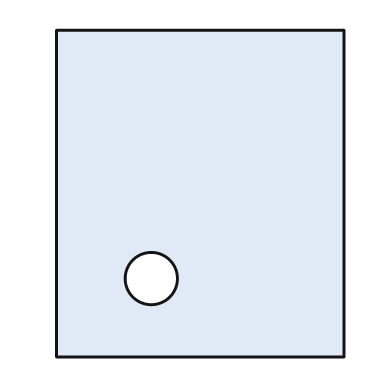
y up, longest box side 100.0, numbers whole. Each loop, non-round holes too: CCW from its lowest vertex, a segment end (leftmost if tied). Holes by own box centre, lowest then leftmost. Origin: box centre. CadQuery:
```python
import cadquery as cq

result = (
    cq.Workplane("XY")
    .moveTo(-44.0, -50.0)
    .lineTo(44.0, -50.0)
    .lineTo(44.0, 50.0)
    .lineTo(-44.0, 50.0)
    .close()
    .moveTo(-15.0, -26.0)
    .circle(8.0)
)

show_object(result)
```